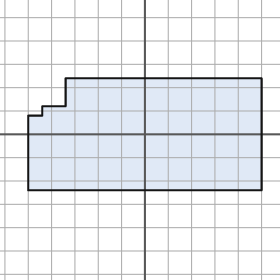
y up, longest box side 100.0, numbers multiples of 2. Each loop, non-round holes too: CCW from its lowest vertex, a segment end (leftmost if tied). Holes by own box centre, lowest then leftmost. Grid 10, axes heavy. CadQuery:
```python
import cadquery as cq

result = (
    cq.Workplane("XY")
    .moveTo(-50.0, -24.0)
    .lineTo(50.0, -24.0)
    .lineTo(50.0, 24.0)
    .lineTo(-34.0, 24.0)
    .lineTo(-34.0, 12.0)
    .lineTo(-44.0, 12.0)
    .lineTo(-44.0, 8.0)
    .lineTo(-50.0, 8.0)
    .close()
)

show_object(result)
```